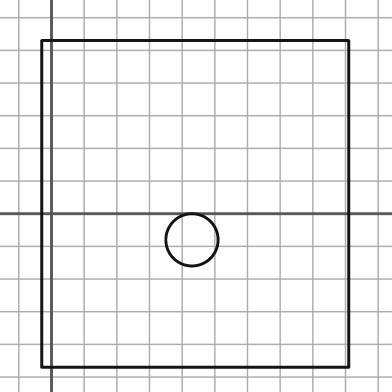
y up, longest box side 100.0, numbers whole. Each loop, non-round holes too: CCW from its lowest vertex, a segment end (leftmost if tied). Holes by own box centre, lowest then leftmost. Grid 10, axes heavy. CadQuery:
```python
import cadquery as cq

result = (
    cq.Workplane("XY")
    .moveTo(-3.0, -47.0)
    .lineTo(91.0, -47.0)
    .lineTo(91.0, 53.0)
    .lineTo(-3.0, 53.0)
    .close()
    .moveTo(43.0, -8.0)
    .circle(8.0)
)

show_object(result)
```